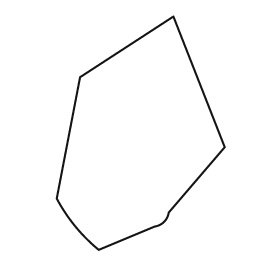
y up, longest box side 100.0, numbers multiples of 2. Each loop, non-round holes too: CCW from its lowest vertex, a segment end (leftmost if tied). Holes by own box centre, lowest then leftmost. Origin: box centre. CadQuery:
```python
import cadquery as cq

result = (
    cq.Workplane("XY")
    .moveTo(-18.0, -50.0)
    .lineTo(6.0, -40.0)
    .threePointArc((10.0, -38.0), (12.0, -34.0))
    .lineTo(36.0, -6.0)
    .lineTo(14.0, 50.0)
    .lineTo(-26.0, 24.0)
    .lineTo(-36.0, -28.0)
    .threePointArc((-28.0, -40.0), (-18.0, -50.0))
    .close()
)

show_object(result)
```